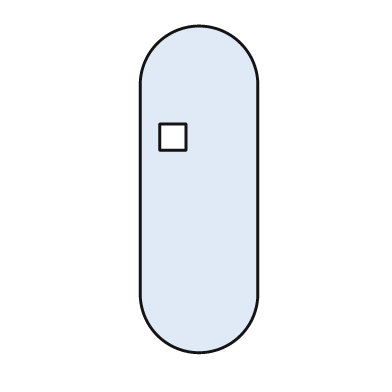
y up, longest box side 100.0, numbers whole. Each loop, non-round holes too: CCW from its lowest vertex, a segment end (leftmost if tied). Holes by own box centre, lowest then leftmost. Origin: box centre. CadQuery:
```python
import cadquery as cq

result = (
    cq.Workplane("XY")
    .moveTo(-18.0, -32.0)
    .threePointArc((0.0, -50.0), (18.0, -32.0))
    .lineTo(18.0, 32.0)
    .threePointArc((0.0, 50.0), (-18.0, 32.0))
    .close()
    .moveTo(-12.0, 12.0)
    .lineTo(-4.0, 12.0)
    .lineTo(-4.0, 20.0)
    .lineTo(-12.0, 20.0)
    .close()
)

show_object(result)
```